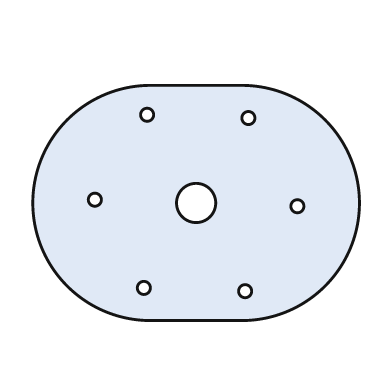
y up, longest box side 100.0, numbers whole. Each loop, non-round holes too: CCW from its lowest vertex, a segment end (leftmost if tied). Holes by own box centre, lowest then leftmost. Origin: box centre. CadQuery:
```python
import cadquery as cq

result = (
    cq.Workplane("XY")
    .moveTo(-14.0, -36.0)
    .lineTo(14.0, -36.0)
    .threePointArc((50.0, 0.0), (14.0, 36.0))
    .lineTo(-14.0, 36.0)
    .threePointArc((-50.0, 0.0), (-14.0, -36.0))
    .close()
    .moveTo(15.0, -27.0)
    .circle(2.0)
    .moveTo(-16.0, -26.0)
    .circle(2.0)
    .moveTo(31.0, -1.0)
    .circle(2.0)
    .moveTo(0.0, 0.0)
    .circle(6.0)
    .moveTo(-31.0, 1.0)
    .circle(2.0)
    .moveTo(16.0, 26.0)
    .circle(2.0)
    .moveTo(-15.0, 27.0)
    .circle(2.0)
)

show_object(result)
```